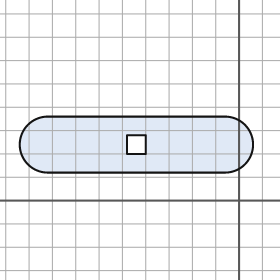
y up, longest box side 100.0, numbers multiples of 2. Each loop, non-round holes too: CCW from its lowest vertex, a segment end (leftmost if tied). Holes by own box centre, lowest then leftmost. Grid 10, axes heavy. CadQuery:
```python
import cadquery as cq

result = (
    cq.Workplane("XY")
    .moveTo(-82.0, 12.0)
    .lineTo(-6.0, 12.0)
    .threePointArc((6.0, 24.0), (-6.0, 36.0))
    .lineTo(-82.0, 36.0)
    .threePointArc((-94.0, 24.0), (-82.0, 12.0))
    .close()
    .moveTo(-48.0, 20.0)
    .lineTo(-40.0, 20.0)
    .lineTo(-40.0, 28.0)
    .lineTo(-48.0, 28.0)
    .close()
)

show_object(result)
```